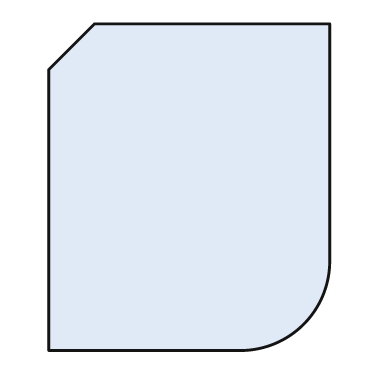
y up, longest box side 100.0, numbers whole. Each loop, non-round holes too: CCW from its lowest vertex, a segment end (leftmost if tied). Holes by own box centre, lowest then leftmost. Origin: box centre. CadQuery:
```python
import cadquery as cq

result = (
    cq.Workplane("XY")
    .moveTo(-43.0, -50.0)
    .lineTo(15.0, -50.0)
    .threePointArc((35.0, -42.0), (43.0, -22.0))
    .lineTo(43.0, 50.0)
    .lineTo(-29.0, 50.0)
    .lineTo(-43.0, 36.0)
    .close()
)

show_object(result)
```